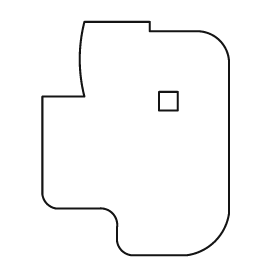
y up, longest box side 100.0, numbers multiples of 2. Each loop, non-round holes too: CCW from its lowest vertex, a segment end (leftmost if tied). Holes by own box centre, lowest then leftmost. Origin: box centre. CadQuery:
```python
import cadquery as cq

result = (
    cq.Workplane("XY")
    .moveTo(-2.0, -50.0)
    .lineTo(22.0, -50.0)
    .threePointArc((34.0, -44.0), (40.0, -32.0))
    .lineTo(40.0, 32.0)
    .threePointArc((36.0, 42.0), (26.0, 46.0))
    .lineTo(6.0, 46.0)
    .lineTo(6.0, 50.0)
    .lineTo(-22.0, 50.0)
    .threePointArc((-24.0, 34.0), (-22.0, 18.0))
    .lineTo(-40.0, 18.0)
    .lineTo(-40.0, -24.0)
    .threePointArc((-38.0, -28.0), (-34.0, -30.0))
    .lineTo(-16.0, -30.0)
    .threePointArc((-10.0, -32.0), (-8.0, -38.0))
    .lineTo(-8.0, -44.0)
    .threePointArc((-6.0, -48.0), (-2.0, -50.0))
    .close()
    .moveTo(10.0, 12.0)
    .lineTo(18.0, 12.0)
    .lineTo(18.0, 20.0)
    .lineTo(10.0, 20.0)
    .close()
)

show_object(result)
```